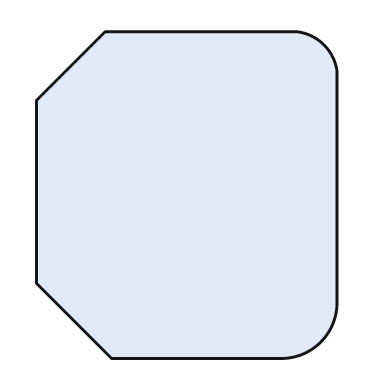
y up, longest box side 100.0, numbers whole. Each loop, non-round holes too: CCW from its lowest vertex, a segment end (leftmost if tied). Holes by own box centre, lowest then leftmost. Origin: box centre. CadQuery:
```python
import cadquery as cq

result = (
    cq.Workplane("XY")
    .moveTo(-23.0, -50.0)
    .lineTo(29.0, -50.0)
    .threePointArc((41.0, -45.0), (46.0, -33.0))
    .lineTo(46.0, 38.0)
    .threePointArc((42.0, 46.0), (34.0, 50.0))
    .lineTo(-25.0, 50.0)
    .lineTo(-46.0, 29.0)
    .lineTo(-46.0, -27.0)
    .close()
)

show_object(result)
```